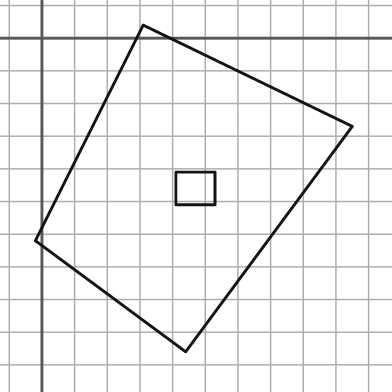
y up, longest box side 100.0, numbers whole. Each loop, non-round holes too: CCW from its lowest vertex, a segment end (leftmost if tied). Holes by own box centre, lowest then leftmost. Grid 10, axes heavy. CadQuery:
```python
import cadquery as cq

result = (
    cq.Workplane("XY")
    .moveTo(44.0, -96.0)
    .lineTo(95.0, -27.0)
    .lineTo(31.0, 4.0)
    .lineTo(-2.0, -62.0)
    .close()
    .moveTo(41.0, -51.0)
    .lineTo(53.0, -51.0)
    .lineTo(53.0, -41.0)
    .lineTo(41.0, -41.0)
    .close()
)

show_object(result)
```